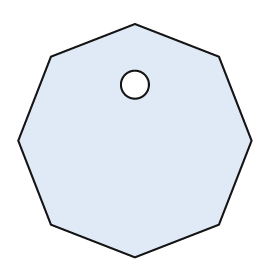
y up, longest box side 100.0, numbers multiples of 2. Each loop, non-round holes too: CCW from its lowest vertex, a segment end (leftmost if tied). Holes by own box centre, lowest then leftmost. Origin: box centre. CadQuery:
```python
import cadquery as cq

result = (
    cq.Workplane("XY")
    .moveTo(0.0, -50.0)
    .lineTo(36.0, -36.0)
    .lineTo(50.0, 0.0)
    .lineTo(36.0, 36.0)
    .lineTo(0.0, 50.0)
    .lineTo(-36.0, 36.0)
    .lineTo(-50.0, 0.0)
    .lineTo(-36.0, -36.0)
    .close()
    .moveTo(0.0, 24.0)
    .circle(6.0)
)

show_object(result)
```